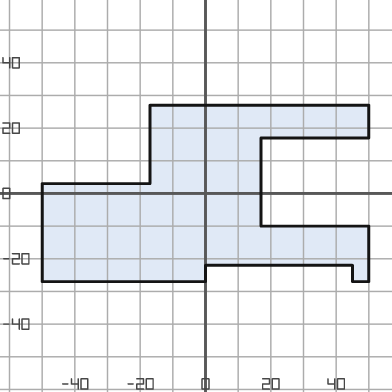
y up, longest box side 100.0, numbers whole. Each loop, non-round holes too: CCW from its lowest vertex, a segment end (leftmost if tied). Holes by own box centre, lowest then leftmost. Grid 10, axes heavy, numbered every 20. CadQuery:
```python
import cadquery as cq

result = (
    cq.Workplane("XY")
    .moveTo(-50.0, -27.0)
    .lineTo(0.0, -27.0)
    .lineTo(0.0, -22.0)
    .lineTo(45.0, -22.0)
    .lineTo(45.0, -27.0)
    .lineTo(50.0, -27.0)
    .lineTo(50.0, -10.0)
    .lineTo(17.0, -10.0)
    .lineTo(17.0, 17.0)
    .lineTo(50.0, 17.0)
    .lineTo(50.0, 27.0)
    .lineTo(-17.0, 27.0)
    .lineTo(-17.0, 3.0)
    .lineTo(-50.0, 3.0)
    .close()
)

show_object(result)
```